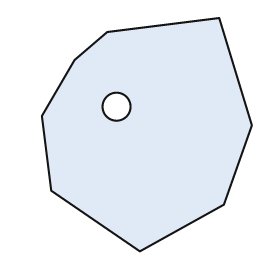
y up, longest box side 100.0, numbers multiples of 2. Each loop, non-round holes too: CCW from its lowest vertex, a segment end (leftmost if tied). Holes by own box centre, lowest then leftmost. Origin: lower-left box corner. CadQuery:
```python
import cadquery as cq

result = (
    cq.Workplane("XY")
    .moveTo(42.0, 0.0)
    .lineTo(78.0, 20.0)
    .lineTo(90.0, 54.0)
    .lineTo(76.0, 100.0)
    .lineTo(28.0, 94.0)
    .lineTo(14.0, 82.0)
    .lineTo(0.0, 58.0)
    .lineTo(4.0, 26.0)
    .close()
    .moveTo(32.0, 62.0)
    .circle(6.0)
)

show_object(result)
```